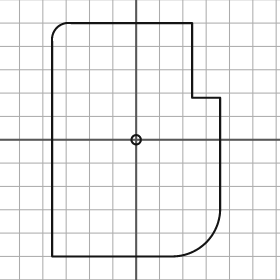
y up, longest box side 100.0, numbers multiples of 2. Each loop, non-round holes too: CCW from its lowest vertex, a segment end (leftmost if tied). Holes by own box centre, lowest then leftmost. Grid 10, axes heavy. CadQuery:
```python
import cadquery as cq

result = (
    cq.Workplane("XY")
    .moveTo(-36.0, -50.0)
    .lineTo(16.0, -50.0)
    .threePointArc((30.0, -44.0), (36.0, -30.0))
    .lineTo(36.0, 18.0)
    .lineTo(24.0, 18.0)
    .lineTo(24.0, 50.0)
    .lineTo(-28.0, 50.0)
    .threePointArc((-34.0, 48.0), (-36.0, 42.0))
    .close()
    .moveTo(0.0, 0.0)
    .circle(2.0)
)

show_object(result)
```